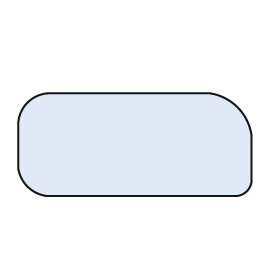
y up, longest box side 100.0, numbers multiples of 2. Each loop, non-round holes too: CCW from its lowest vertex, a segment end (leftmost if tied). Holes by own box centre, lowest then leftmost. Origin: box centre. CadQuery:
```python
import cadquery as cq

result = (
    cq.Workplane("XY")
    .moveTo(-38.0, -22.0)
    .lineTo(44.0, -22.0)
    .threePointArc((48.0, -20.0), (50.0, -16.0))
    .lineTo(50.0, 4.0)
    .threePointArc((44.0, 16.0), (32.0, 22.0))
    .lineTo(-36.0, 22.0)
    .threePointArc((-46.0, 18.0), (-50.0, 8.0))
    .lineTo(-50.0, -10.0)
    .threePointArc((-46.0, -18.0), (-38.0, -22.0))
    .close()
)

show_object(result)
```